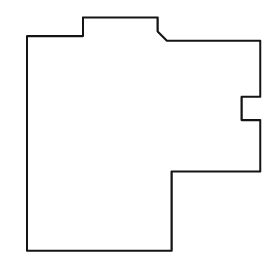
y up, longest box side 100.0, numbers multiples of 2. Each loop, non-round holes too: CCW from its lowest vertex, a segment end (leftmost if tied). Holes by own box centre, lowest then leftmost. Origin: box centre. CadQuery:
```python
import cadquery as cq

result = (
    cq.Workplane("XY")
    .moveTo(-50.0, -50.0)
    .lineTo(12.0, -50.0)
    .lineTo(12.0, -16.0)
    .lineTo(50.0, -16.0)
    .lineTo(50.0, 6.0)
    .lineTo(42.0, 6.0)
    .lineTo(42.0, 16.0)
    .lineTo(50.0, 16.0)
    .lineTo(50.0, 40.0)
    .lineTo(10.0, 40.0)
    .lineTo(6.0, 44.0)
    .lineTo(6.0, 50.0)
    .lineTo(-26.0, 50.0)
    .lineTo(-26.0, 42.0)
    .lineTo(-50.0, 42.0)
    .close()
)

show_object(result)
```